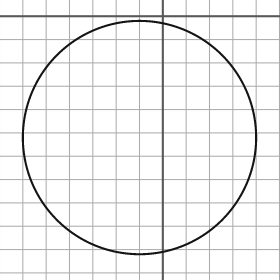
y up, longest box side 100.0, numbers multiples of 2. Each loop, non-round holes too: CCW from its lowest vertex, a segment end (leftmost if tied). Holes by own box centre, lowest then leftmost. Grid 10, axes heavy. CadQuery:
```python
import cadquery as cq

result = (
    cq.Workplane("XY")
    .moveTo(-10.0, -52.0)
    .circle(50.0)
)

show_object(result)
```